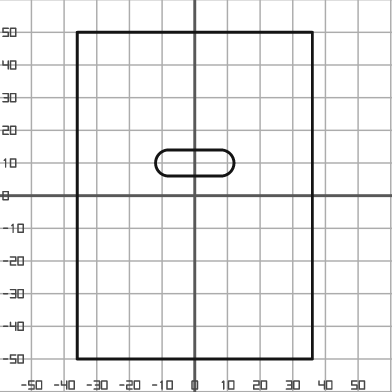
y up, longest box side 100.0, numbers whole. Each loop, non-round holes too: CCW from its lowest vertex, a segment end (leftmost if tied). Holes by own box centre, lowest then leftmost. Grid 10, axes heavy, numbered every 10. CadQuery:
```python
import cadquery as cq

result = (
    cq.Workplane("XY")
    .moveTo(-36.0, -50.0)
    .lineTo(36.0, -50.0)
    .lineTo(36.0, 50.0)
    .lineTo(-36.0, 50.0)
    .close()
    .moveTo(-8.0, 6.0)
    .lineTo(8.0, 6.0)
    .threePointArc((12.0, 10.0), (8.0, 14.0))
    .lineTo(-8.0, 14.0)
    .threePointArc((-12.0, 10.0), (-8.0, 6.0))
    .close()
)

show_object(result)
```